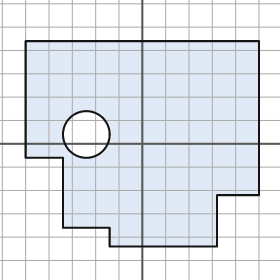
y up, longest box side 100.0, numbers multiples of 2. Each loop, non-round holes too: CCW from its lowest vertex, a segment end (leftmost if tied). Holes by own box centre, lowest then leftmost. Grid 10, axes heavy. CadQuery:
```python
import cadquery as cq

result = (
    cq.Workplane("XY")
    .moveTo(-14.0, -44.0)
    .lineTo(32.0, -44.0)
    .lineTo(32.0, -22.0)
    .lineTo(50.0, -22.0)
    .lineTo(50.0, 44.0)
    .lineTo(-50.0, 44.0)
    .lineTo(-50.0, -6.0)
    .lineTo(-34.0, -6.0)
    .lineTo(-34.0, -36.0)
    .lineTo(-14.0, -36.0)
    .close()
    .moveTo(-24.0, 4.0)
    .circle(10.0)
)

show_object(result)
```